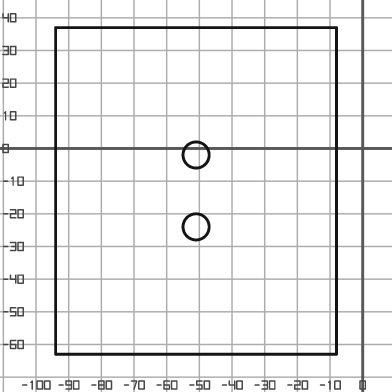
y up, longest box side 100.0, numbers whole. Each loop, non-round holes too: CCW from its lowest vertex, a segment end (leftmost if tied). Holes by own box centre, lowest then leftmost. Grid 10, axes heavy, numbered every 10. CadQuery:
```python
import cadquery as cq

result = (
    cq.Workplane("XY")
    .moveTo(-94.0, -63.0)
    .lineTo(-8.0, -63.0)
    .lineTo(-8.0, 37.0)
    .lineTo(-94.0, 37.0)
    .close()
    .moveTo(-51.0, -24.0)
    .circle(4.0)
    .moveTo(-51.0, -2.0)
    .circle(4.0)
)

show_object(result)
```